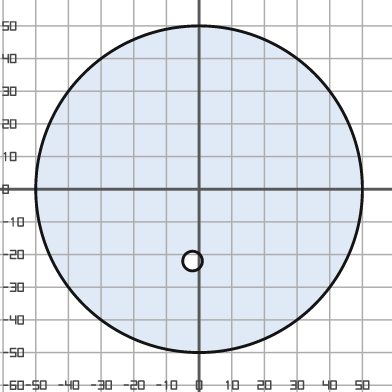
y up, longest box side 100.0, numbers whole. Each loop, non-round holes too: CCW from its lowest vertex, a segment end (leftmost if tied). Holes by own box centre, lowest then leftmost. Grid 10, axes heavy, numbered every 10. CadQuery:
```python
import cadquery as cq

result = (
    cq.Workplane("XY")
    .moveTo(0.0, 0.0)
    .circle(50.0)
    .moveTo(-2.0, -22.0)
    .circle(3.0)
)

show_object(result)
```